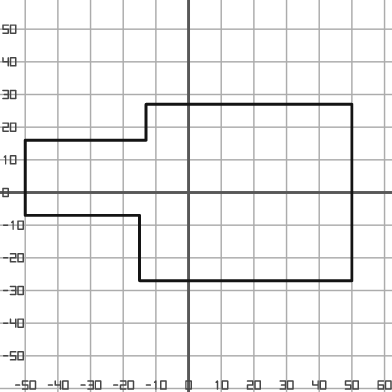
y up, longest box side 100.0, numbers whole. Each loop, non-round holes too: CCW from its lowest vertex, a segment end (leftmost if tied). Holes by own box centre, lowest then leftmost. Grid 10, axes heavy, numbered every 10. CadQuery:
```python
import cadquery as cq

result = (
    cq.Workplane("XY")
    .moveTo(-15.0, -27.0)
    .lineTo(50.0, -27.0)
    .lineTo(50.0, 27.0)
    .lineTo(-13.0, 27.0)
    .lineTo(-13.0, 16.0)
    .lineTo(-50.0, 16.0)
    .lineTo(-50.0, -7.0)
    .lineTo(-15.0, -7.0)
    .close()
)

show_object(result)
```